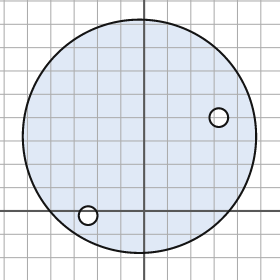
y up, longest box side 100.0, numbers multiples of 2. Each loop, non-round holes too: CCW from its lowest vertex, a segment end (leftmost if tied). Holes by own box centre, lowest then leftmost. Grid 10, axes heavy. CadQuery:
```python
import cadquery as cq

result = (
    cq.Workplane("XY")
    .moveTo(-2.0, 32.0)
    .circle(50.0)
    .moveTo(-24.0, -2.0)
    .circle(4.0)
    .moveTo(32.0, 40.0)
    .circle(4.0)
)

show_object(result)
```